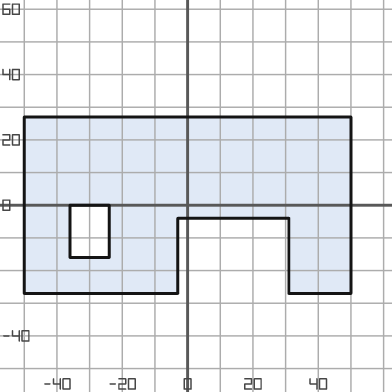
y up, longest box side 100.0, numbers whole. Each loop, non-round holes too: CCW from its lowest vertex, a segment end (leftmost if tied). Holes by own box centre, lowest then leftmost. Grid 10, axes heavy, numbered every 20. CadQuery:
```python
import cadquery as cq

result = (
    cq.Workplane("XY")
    .moveTo(-50.0, -27.0)
    .lineTo(-3.0, -27.0)
    .lineTo(-3.0, -4.0)
    .lineTo(31.0, -4.0)
    .lineTo(31.0, -27.0)
    .lineTo(50.0, -27.0)
    .lineTo(50.0, 27.0)
    .lineTo(-50.0, 27.0)
    .close()
    .moveTo(-36.0, -16.0)
    .lineTo(-24.0, -16.0)
    .lineTo(-24.0, 0.0)
    .lineTo(-36.0, 0.0)
    .close()
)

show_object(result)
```